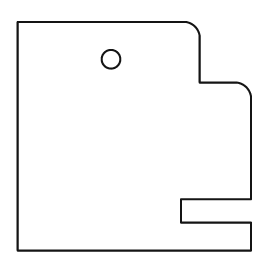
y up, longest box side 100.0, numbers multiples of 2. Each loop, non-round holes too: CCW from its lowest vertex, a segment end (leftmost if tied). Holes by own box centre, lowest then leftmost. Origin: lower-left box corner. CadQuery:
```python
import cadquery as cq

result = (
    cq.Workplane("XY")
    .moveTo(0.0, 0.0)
    .lineTo(100.0, 0.0)
    .lineTo(100.0, 12.0)
    .lineTo(70.0, 12.0)
    .lineTo(70.0, 22.0)
    .lineTo(100.0, 22.0)
    .lineTo(100.0, 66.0)
    .threePointArc((98.0, 70.0), (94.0, 72.0))
    .lineTo(78.0, 72.0)
    .lineTo(78.0, 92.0)
    .threePointArc((76.0, 96.0), (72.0, 98.0))
    .lineTo(0.0, 98.0)
    .close()
    .moveTo(40.0, 82.0)
    .circle(4.0)
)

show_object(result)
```